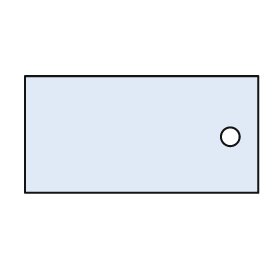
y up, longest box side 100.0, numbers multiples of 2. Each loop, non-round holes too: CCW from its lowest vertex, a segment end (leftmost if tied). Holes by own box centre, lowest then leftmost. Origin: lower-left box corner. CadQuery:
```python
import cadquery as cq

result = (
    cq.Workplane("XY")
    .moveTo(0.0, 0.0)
    .lineTo(100.0, 0.0)
    .lineTo(100.0, 50.0)
    .lineTo(0.0, 50.0)
    .close()
    .moveTo(88.0, 24.0)
    .circle(4.0)
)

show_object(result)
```